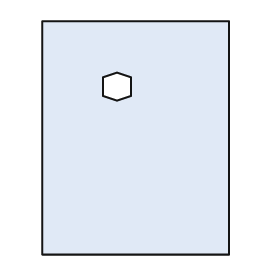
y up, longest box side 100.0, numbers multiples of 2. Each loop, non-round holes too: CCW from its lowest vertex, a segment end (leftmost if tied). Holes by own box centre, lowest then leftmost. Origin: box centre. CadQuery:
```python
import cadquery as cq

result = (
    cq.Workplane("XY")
    .moveTo(-40.0, -50.0)
    .lineTo(40.0, -50.0)
    .lineTo(40.0, 50.0)
    .lineTo(-40.0, 50.0)
    .close()
    .moveTo(-8.0, 16.0)
    .lineTo(-2.0, 18.0)
    .lineTo(-2.0, 26.0)
    .lineTo(-8.0, 28.0)
    .lineTo(-14.0, 26.0)
    .lineTo(-14.0, 18.0)
    .close()
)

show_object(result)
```